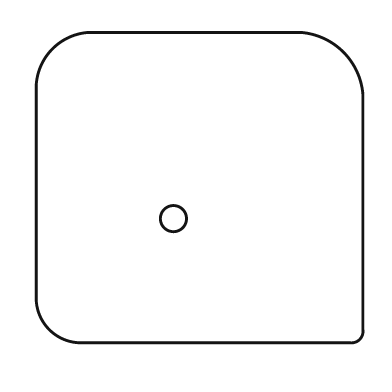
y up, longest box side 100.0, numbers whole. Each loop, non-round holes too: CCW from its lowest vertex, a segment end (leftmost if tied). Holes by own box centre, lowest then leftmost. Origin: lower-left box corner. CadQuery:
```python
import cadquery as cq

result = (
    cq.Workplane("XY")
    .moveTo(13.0, 0.0)
    .lineTo(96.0, 0.0)
    .threePointArc((99.0, 1.0), (100.0, 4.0))
    .lineTo(100.0, 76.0)
    .threePointArc((94.0, 89.0), (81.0, 95.0))
    .lineTo(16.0, 95.0)
    .threePointArc((5.0, 90.0), (0.0, 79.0))
    .lineTo(0.0, 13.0)
    .threePointArc((4.0, 4.0), (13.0, 0.0))
    .close()
    .moveTo(42.0, 38.0)
    .circle(4.0)
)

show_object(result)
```